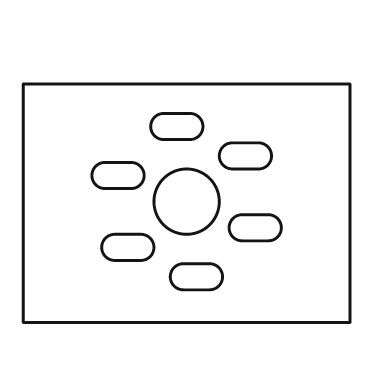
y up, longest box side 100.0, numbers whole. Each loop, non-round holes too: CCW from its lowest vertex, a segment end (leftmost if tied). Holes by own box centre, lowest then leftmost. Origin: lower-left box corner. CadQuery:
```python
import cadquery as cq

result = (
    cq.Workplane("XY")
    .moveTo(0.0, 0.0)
    .lineTo(100.0, 0.0)
    .lineTo(100.0, 73.0)
    .lineTo(0.0, 73.0)
    .close()
    .moveTo(49.0, 10.0)
    .lineTo(57.0, 10.0)
    .threePointArc((61.0, 14.0), (57.0, 18.0))
    .lineTo(49.0, 18.0)
    .threePointArc((45.0, 14.0), (49.0, 10.0))
    .close()
    .moveTo(28.0, 19.0)
    .lineTo(36.0, 19.0)
    .threePointArc((40.0, 23.0), (36.0, 27.0))
    .lineTo(28.0, 27.0)
    .threePointArc((24.0, 23.0), (28.0, 19.0))
    .close()
    .moveTo(67.0, 25.0)
    .lineTo(75.0, 25.0)
    .threePointArc((79.0, 29.0), (75.0, 33.0))
    .lineTo(67.0, 33.0)
    .threePointArc((63.0, 29.0), (67.0, 25.0))
    .close()
    .moveTo(50.0, 37.0)
    .circle(10.0)
    .moveTo(25.0, 41.0)
    .lineTo(33.0, 41.0)
    .threePointArc((37.0, 45.0), (33.0, 49.0))
    .lineTo(25.0, 49.0)
    .threePointArc((21.0, 45.0), (25.0, 41.0))
    .close()
    .moveTo(64.0, 47.0)
    .lineTo(72.0, 47.0)
    .threePointArc((76.0, 51.0), (72.0, 55.0))
    .lineTo(64.0, 55.0)
    .threePointArc((60.0, 51.0), (64.0, 47.0))
    .close()
    .moveTo(43.0, 56.0)
    .lineTo(51.0, 56.0)
    .threePointArc((55.0, 60.0), (51.0, 64.0))
    .lineTo(43.0, 64.0)
    .threePointArc((39.0, 60.0), (43.0, 56.0))
    .close()
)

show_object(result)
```